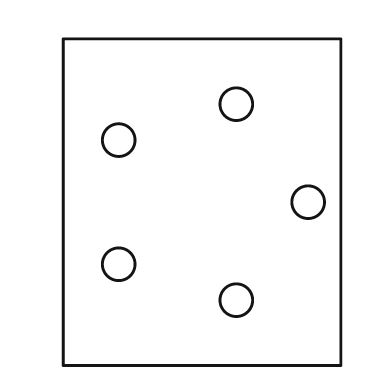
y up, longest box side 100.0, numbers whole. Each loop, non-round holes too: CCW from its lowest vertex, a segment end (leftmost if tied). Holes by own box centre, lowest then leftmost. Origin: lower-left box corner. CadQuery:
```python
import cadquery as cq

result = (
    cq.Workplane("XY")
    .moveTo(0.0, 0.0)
    .lineTo(85.0, 0.0)
    .lineTo(85.0, 100.0)
    .lineTo(0.0, 100.0)
    .close()
    .moveTo(53.0, 20.0)
    .circle(5.0)
    .moveTo(17.0, 31.0)
    .circle(5.0)
    .moveTo(75.0, 50.0)
    .circle(5.0)
    .moveTo(17.0, 69.0)
    .circle(5.0)
    .moveTo(53.0, 80.0)
    .circle(5.0)
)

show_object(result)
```